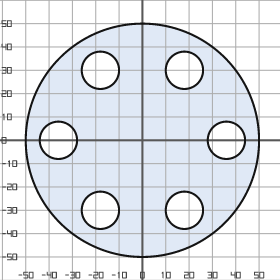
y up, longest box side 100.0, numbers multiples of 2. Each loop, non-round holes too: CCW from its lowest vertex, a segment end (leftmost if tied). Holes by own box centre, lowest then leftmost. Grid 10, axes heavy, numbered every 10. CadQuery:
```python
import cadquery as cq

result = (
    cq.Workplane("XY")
    .moveTo(0.0, 0.0)
    .circle(50.0)
    .moveTo(-18.0, -30.0)
    .circle(8.0)
    .moveTo(18.0, -30.0)
    .circle(8.0)
    .moveTo(-36.0, 0.0)
    .circle(8.0)
    .moveTo(36.0, 0.0)
    .circle(8.0)
    .moveTo(-18.0, 30.0)
    .circle(8.0)
    .moveTo(18.0, 30.0)
    .circle(8.0)
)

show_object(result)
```